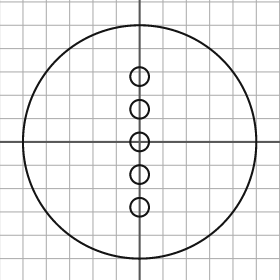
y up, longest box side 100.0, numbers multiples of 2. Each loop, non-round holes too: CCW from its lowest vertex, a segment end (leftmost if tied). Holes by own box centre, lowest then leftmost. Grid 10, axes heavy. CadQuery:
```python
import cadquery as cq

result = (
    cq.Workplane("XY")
    .moveTo(0.0, 0.0)
    .circle(50.0)
    .moveTo(0.0, -28.0)
    .circle(4.0)
    .moveTo(0.0, -14.0)
    .circle(4.0)
    .moveTo(0.0, 0.0)
    .circle(4.0)
    .moveTo(0.0, 14.0)
    .circle(4.0)
    .moveTo(0.0, 28.0)
    .circle(4.0)
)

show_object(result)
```